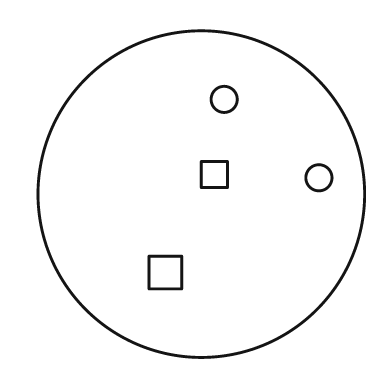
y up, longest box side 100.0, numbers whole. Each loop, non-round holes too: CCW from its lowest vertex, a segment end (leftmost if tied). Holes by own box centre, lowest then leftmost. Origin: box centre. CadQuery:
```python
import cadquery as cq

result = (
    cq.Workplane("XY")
    .moveTo(0.0, 0.0)
    .circle(50.0)
    .moveTo(-16.0, -29.0)
    .lineTo(-6.0, -29.0)
    .lineTo(-6.0, -19.0)
    .lineTo(-16.0, -19.0)
    .close()
    .moveTo(36.0, 5.0)
    .circle(4.0)
    .moveTo(0.0, 2.0)
    .lineTo(8.0, 2.0)
    .lineTo(8.0, 10.0)
    .lineTo(0.0, 10.0)
    .close()
    .moveTo(7.0, 29.0)
    .circle(4.0)
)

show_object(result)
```